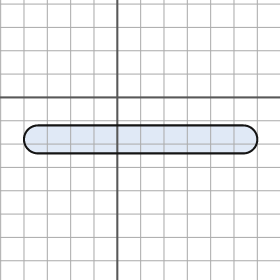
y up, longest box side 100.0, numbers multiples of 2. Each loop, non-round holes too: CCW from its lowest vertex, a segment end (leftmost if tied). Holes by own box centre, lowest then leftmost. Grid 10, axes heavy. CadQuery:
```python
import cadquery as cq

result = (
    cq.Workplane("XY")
    .moveTo(-34.0, -24.0)
    .lineTo(54.0, -24.0)
    .threePointArc((60.0, -18.0), (54.0, -12.0))
    .lineTo(-34.0, -12.0)
    .threePointArc((-40.0, -18.0), (-34.0, -24.0))
    .close()
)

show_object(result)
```